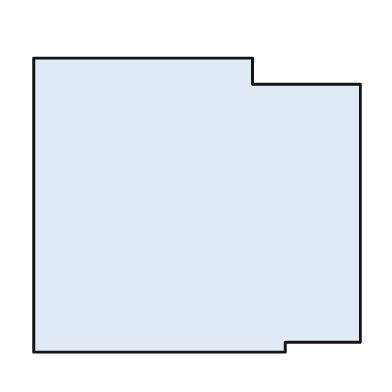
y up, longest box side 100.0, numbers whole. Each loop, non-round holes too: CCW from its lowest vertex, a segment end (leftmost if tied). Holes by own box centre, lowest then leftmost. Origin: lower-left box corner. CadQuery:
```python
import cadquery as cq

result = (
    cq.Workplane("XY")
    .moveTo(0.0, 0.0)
    .lineTo(77.0, 0.0)
    .lineTo(77.0, 3.0)
    .lineTo(100.0, 3.0)
    .lineTo(100.0, 82.0)
    .lineTo(67.0, 82.0)
    .lineTo(67.0, 90.0)
    .lineTo(0.0, 90.0)
    .close()
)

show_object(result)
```